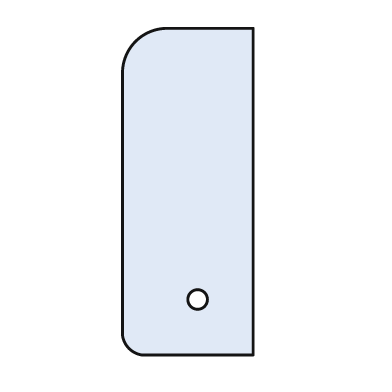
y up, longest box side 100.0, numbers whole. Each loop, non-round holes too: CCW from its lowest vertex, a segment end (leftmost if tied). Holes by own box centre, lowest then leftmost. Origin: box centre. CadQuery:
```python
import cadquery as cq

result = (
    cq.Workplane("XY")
    .moveTo(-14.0, -50.0)
    .lineTo(20.0, -50.0)
    .lineTo(20.0, 50.0)
    .lineTo(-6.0, 50.0)
    .threePointArc((-16.0, 46.0), (-20.0, 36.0))
    .lineTo(-20.0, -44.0)
    .threePointArc((-18.0, -48.0), (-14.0, -50.0))
    .close()
    .moveTo(3.0, -33.0)
    .circle(3.0)
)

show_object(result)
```